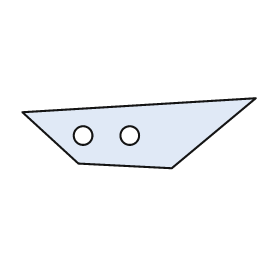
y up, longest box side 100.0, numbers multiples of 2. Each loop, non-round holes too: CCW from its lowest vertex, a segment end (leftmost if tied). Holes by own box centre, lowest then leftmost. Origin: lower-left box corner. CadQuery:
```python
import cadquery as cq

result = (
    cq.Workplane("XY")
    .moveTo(64.0, 0.0)
    .lineTo(100.0, 30.0)
    .lineTo(0.0, 24.0)
    .lineTo(24.0, 2.0)
    .close()
    .moveTo(26.0, 14.0)
    .circle(4.0)
    .moveTo(46.0, 14.0)
    .circle(4.0)
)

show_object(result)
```